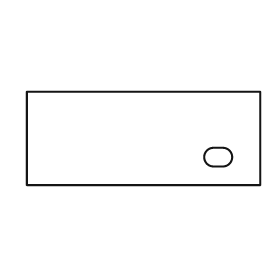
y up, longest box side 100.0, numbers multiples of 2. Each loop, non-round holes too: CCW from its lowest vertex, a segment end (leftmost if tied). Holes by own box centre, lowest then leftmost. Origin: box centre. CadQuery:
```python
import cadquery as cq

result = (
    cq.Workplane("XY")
    .moveTo(-50.0, -20.0)
    .lineTo(50.0, -20.0)
    .lineTo(50.0, 20.0)
    .lineTo(-50.0, 20.0)
    .close()
    .moveTo(30.0, -12.0)
    .lineTo(34.0, -12.0)
    .threePointArc((38.0, -8.0), (34.0, -4.0))
    .lineTo(30.0, -4.0)
    .threePointArc((26.0, -8.0), (30.0, -12.0))
    .close()
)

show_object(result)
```